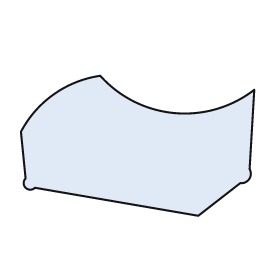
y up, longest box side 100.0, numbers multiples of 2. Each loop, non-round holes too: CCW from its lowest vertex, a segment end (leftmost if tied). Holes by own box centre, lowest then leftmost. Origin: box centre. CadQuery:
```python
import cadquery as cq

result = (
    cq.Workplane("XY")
    .moveTo(26.0, -30.0)
    .lineTo(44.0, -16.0)
    .threePointArc((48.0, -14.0), (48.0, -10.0))
    .lineTo(50.0, 24.0)
    .threePointArc((16.0, 14.0), (-16.0, 30.0))
    .threePointArc((-36.0, 22.0), (-50.0, 6.0))
    .lineTo(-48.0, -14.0)
    .threePointArc((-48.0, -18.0), (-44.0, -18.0))
    .close()
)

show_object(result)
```